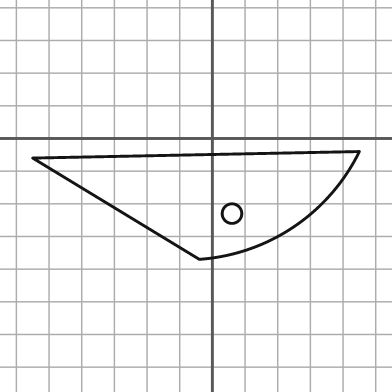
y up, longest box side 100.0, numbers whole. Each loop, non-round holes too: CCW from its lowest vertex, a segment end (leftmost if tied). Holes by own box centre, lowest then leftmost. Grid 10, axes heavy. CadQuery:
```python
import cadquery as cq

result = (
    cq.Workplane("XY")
    .moveTo(-4.0, -37.0)
    .threePointArc((25.0, -27.0), (45.0, -4.0))
    .lineTo(-55.0, -6.0)
    .close()
    .moveTo(6.0, -23.0)
    .circle(3.0)
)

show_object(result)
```